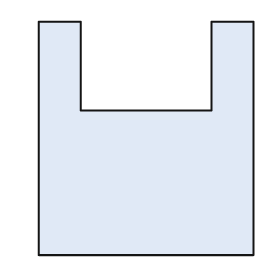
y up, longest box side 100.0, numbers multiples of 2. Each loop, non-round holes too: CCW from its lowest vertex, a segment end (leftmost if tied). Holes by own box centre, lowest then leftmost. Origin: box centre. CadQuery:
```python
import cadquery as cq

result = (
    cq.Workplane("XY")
    .moveTo(-46.0, -50.0)
    .lineTo(46.0, -50.0)
    .lineTo(46.0, 50.0)
    .lineTo(28.0, 50.0)
    .lineTo(28.0, 12.0)
    .lineTo(-28.0, 12.0)
    .lineTo(-28.0, 50.0)
    .lineTo(-46.0, 50.0)
    .close()
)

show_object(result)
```